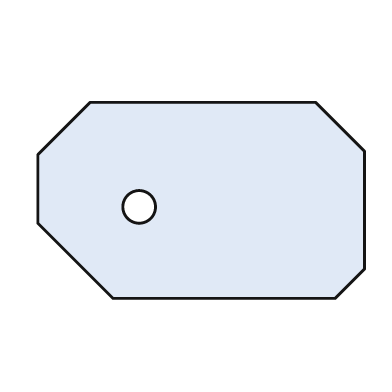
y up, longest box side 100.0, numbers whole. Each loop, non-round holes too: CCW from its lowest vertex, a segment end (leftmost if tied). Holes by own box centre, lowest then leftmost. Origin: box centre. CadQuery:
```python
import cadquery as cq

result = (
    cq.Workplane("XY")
    .moveTo(-27.0, -30.0)
    .lineTo(41.0, -30.0)
    .lineTo(50.0, -21.0)
    .lineTo(50.0, 15.0)
    .lineTo(35.0, 30.0)
    .lineTo(-34.0, 30.0)
    .lineTo(-50.0, 14.0)
    .lineTo(-50.0, -7.0)
    .close()
    .moveTo(-19.0, -2.0)
    .circle(5.0)
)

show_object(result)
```